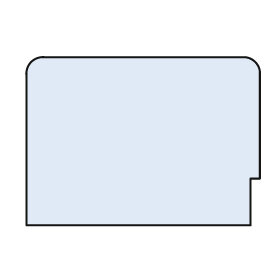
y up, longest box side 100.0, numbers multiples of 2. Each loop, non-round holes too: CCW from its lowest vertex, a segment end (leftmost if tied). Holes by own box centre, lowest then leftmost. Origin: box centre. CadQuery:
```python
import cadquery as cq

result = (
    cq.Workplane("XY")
    .moveTo(-50.0, -36.0)
    .lineTo(46.0, -36.0)
    .lineTo(46.0, -16.0)
    .lineTo(50.0, -16.0)
    .lineTo(50.0, 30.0)
    .threePointArc((48.0, 34.0), (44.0, 36.0))
    .lineTo(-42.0, 36.0)
    .threePointArc((-48.0, 34.0), (-50.0, 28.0))
    .close()
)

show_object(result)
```